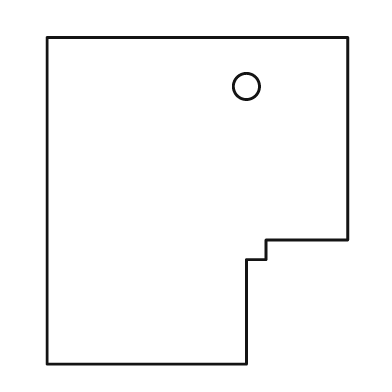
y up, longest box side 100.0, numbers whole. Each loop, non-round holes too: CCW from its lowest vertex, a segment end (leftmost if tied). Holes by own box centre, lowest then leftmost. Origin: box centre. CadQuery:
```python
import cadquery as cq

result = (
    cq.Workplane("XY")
    .moveTo(-46.0, -50.0)
    .lineTo(15.0, -50.0)
    .lineTo(15.0, -18.0)
    .lineTo(21.0, -18.0)
    .lineTo(21.0, -12.0)
    .lineTo(46.0, -12.0)
    .lineTo(46.0, 50.0)
    .lineTo(-46.0, 50.0)
    .close()
    .moveTo(15.0, 35.0)
    .circle(4.0)
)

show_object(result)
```